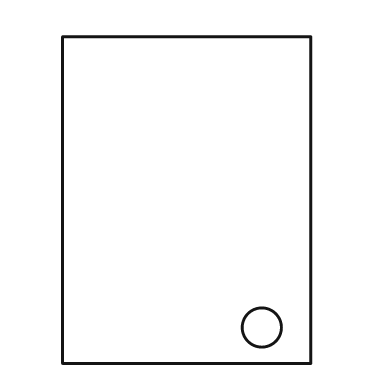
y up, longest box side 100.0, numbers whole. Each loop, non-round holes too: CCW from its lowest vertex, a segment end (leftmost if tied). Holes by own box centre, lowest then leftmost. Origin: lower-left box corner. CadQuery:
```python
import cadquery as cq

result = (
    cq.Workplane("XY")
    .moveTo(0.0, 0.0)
    .lineTo(76.0, 0.0)
    .lineTo(76.0, 100.0)
    .lineTo(0.0, 100.0)
    .close()
    .moveTo(61.0, 11.0)
    .circle(6.0)
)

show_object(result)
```